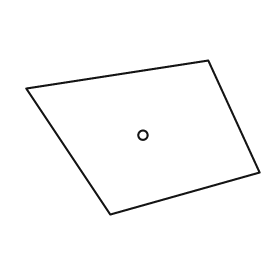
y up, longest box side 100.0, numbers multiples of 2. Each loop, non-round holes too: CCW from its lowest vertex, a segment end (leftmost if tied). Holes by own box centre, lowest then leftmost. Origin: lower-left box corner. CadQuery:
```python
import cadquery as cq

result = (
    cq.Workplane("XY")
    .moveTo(36.0, 0.0)
    .lineTo(100.0, 18.0)
    .lineTo(78.0, 66.0)
    .lineTo(0.0, 54.0)
    .close()
    .moveTo(50.0, 34.0)
    .circle(2.0)
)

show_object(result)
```